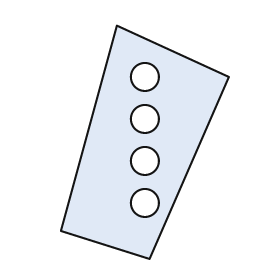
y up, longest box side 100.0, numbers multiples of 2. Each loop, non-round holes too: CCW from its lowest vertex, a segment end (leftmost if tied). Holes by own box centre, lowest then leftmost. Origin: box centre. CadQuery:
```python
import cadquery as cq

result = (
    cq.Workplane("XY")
    .moveTo(2.0, -50.0)
    .lineTo(36.0, 28.0)
    .lineTo(-12.0, 50.0)
    .lineTo(-36.0, -38.0)
    .close()
    .moveTo(0.0, -26.0)
    .circle(6.0)
    .moveTo(0.0, -8.0)
    .circle(6.0)
    .moveTo(0.0, 10.0)
    .circle(6.0)
    .moveTo(0.0, 28.0)
    .circle(6.0)
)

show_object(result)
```